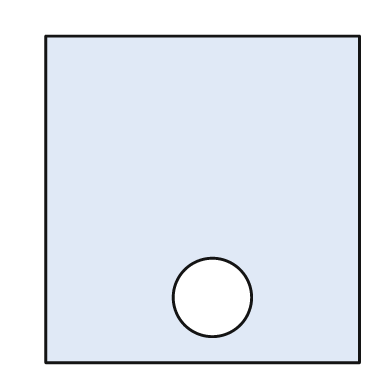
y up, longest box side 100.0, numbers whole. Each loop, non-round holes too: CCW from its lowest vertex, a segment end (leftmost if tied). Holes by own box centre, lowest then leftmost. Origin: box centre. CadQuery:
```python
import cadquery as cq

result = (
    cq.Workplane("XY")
    .moveTo(-48.0, -50.0)
    .lineTo(48.0, -50.0)
    .lineTo(48.0, 50.0)
    .lineTo(-48.0, 50.0)
    .close()
    .moveTo(3.0, -30.0)
    .circle(12.0)
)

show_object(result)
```